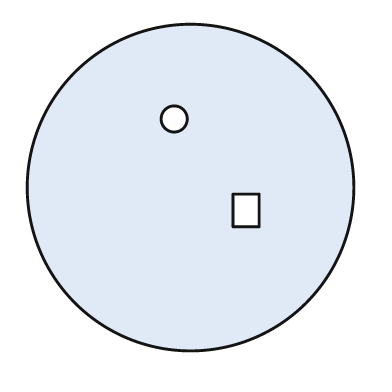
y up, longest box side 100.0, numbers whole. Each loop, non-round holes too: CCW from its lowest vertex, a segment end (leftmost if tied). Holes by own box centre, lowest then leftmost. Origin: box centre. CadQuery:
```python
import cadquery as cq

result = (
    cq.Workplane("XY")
    .moveTo(0.0, 0.0)
    .circle(50.0)
    .moveTo(13.0, -12.0)
    .lineTo(21.0, -12.0)
    .lineTo(21.0, -2.0)
    .lineTo(13.0, -2.0)
    .close()
    .moveTo(-5.0, 21.0)
    .circle(4.0)
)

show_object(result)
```